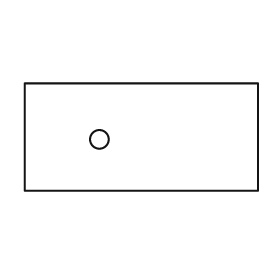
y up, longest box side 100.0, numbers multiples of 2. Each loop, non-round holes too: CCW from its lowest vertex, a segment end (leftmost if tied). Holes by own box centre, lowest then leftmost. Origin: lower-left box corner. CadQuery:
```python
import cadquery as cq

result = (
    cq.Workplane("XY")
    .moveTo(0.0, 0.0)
    .lineTo(100.0, 0.0)
    .lineTo(100.0, 46.0)
    .lineTo(0.0, 46.0)
    .close()
    .moveTo(32.0, 22.0)
    .circle(4.0)
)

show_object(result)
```